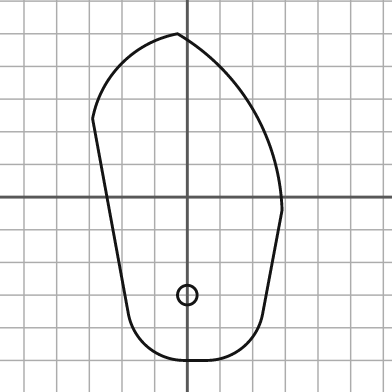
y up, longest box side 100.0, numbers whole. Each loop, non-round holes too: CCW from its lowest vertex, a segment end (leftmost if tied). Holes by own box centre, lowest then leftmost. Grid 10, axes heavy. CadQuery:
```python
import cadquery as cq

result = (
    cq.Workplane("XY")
    .moveTo(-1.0, -50.0)
    .lineTo(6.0, -50.0)
    .threePointArc((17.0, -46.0), (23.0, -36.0))
    .lineTo(29.0, -4.0)
    .threePointArc((20.0, 27.0), (-3.0, 50.0))
    .threePointArc((-20.0, 41.0), (-29.0, 24.0))
    .lineTo(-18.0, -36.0)
    .threePointArc((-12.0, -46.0), (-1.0, -50.0))
    .close()
    .moveTo(0.0, -30.0)
    .circle(3.0)
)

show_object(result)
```